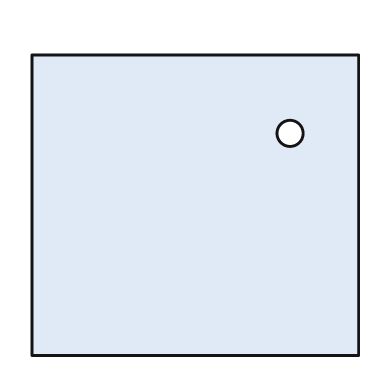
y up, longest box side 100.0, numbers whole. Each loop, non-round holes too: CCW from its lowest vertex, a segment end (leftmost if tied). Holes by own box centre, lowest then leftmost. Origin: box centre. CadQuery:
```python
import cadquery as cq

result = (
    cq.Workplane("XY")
    .moveTo(-50.0, -46.0)
    .lineTo(50.0, -46.0)
    .lineTo(50.0, 46.0)
    .lineTo(-50.0, 46.0)
    .close()
    .moveTo(29.0, 22.0)
    .circle(4.0)
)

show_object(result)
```